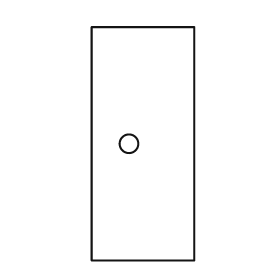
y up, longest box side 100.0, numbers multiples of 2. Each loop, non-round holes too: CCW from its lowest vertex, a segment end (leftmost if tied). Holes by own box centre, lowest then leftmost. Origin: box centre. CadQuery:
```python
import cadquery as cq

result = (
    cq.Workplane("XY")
    .moveTo(-22.0, -50.0)
    .lineTo(22.0, -50.0)
    .lineTo(22.0, 50.0)
    .lineTo(-22.0, 50.0)
    .close()
    .moveTo(-6.0, 0.0)
    .circle(4.0)
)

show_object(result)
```